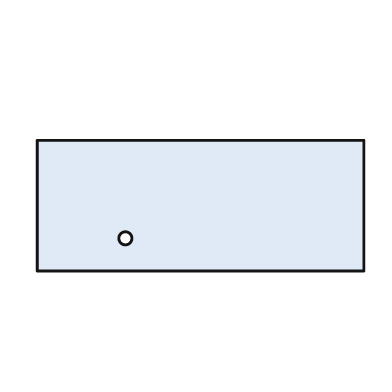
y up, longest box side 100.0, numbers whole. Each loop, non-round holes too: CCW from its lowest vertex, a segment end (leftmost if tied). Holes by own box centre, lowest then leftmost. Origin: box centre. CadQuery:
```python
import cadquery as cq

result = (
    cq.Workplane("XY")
    .moveTo(-50.0, -20.0)
    .lineTo(50.0, -20.0)
    .lineTo(50.0, 20.0)
    .lineTo(-50.0, 20.0)
    .close()
    .moveTo(-23.0, -10.0)
    .circle(2.0)
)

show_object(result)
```